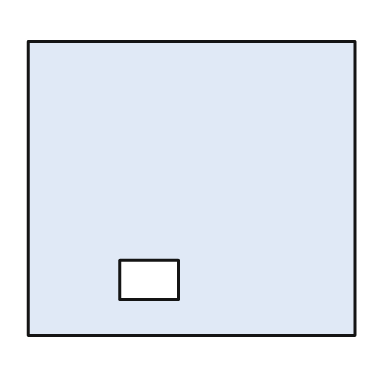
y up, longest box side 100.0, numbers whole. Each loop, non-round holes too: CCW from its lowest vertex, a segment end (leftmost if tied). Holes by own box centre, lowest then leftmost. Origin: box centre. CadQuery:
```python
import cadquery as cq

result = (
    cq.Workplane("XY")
    .moveTo(-50.0, -45.0)
    .lineTo(50.0, -45.0)
    .lineTo(50.0, 45.0)
    .lineTo(-50.0, 45.0)
    .close()
    .moveTo(-22.0, -34.0)
    .lineTo(-4.0, -34.0)
    .lineTo(-4.0, -22.0)
    .lineTo(-22.0, -22.0)
    .close()
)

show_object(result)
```